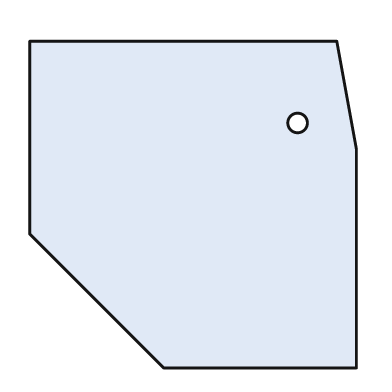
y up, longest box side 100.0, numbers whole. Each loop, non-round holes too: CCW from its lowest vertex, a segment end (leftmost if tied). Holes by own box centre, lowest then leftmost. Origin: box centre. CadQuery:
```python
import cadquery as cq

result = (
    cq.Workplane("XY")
    .moveTo(-9.0, -50.0)
    .lineTo(50.0, -50.0)
    .lineTo(50.0, 17.0)
    .lineTo(44.0, 50.0)
    .lineTo(-50.0, 50.0)
    .lineTo(-50.0, -9.0)
    .close()
    .moveTo(32.0, 25.0)
    .circle(3.0)
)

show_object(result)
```